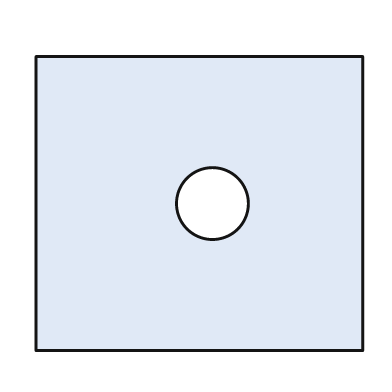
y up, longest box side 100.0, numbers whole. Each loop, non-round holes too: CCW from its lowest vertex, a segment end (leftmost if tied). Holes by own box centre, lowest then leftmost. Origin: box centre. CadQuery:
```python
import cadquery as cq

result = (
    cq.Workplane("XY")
    .moveTo(-50.0, -45.0)
    .lineTo(50.0, -45.0)
    .lineTo(50.0, 45.0)
    .lineTo(-50.0, 45.0)
    .close()
    .moveTo(4.0, 0.0)
    .circle(11.0)
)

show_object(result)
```